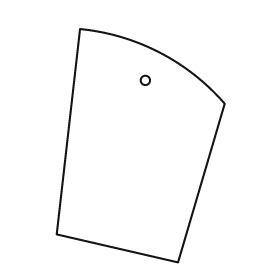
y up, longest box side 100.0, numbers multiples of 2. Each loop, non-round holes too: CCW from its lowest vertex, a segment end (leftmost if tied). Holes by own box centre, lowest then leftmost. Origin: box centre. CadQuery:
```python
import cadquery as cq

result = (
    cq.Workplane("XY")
    .moveTo(16.0, -50.0)
    .lineTo(36.0, 18.0)
    .threePointArc((8.0, 40.0), (-26.0, 50.0))
    .lineTo(-36.0, -38.0)
    .close()
    .moveTo(2.0, 28.0)
    .circle(2.0)
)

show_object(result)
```